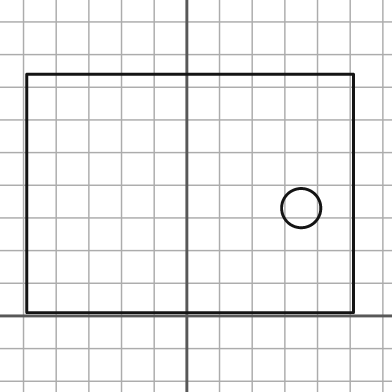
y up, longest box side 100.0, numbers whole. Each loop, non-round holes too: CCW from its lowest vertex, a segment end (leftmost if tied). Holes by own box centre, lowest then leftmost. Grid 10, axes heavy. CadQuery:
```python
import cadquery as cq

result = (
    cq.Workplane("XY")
    .moveTo(-49.0, 1.0)
    .lineTo(51.0, 1.0)
    .lineTo(51.0, 74.0)
    .lineTo(-49.0, 74.0)
    .close()
    .moveTo(35.0, 33.0)
    .circle(6.0)
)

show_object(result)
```